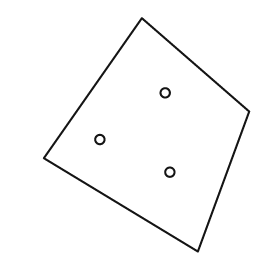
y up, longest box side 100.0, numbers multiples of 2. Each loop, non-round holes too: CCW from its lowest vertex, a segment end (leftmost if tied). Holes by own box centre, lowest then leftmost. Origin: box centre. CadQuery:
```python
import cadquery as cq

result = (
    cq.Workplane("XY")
    .moveTo(22.0, -50.0)
    .lineTo(44.0, 10.0)
    .lineTo(-2.0, 50.0)
    .lineTo(-44.0, -10.0)
    .close()
    .moveTo(10.0, -16.0)
    .circle(2.0)
    .moveTo(-20.0, -2.0)
    .circle(2.0)
    .moveTo(8.0, 18.0)
    .circle(2.0)
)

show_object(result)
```